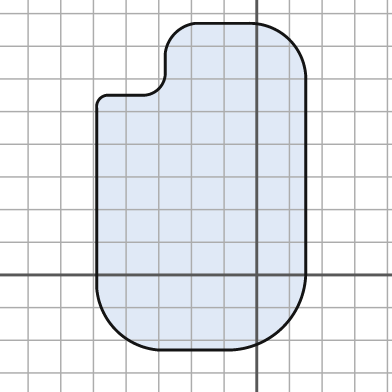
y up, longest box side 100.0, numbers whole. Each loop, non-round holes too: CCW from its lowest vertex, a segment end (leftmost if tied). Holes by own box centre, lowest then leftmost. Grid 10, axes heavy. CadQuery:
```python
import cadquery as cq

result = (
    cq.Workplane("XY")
    .moveTo(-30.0, -23.0)
    .lineTo(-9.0, -23.0)
    .threePointArc((8.0, -16.0), (15.0, 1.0))
    .lineTo(15.0, 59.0)
    .threePointArc((10.0, 72.0), (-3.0, 77.0))
    .lineTo(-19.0, 77.0)
    .threePointArc((-25.0, 74.0), (-28.0, 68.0))
    .lineTo(-28.0, 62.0)
    .threePointArc((-30.0, 57.0), (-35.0, 55.0))
    .lineTo(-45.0, 55.0)
    .threePointArc((-48.0, 54.0), (-49.0, 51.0))
    .lineTo(-49.0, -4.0)
    .threePointArc((-43.0, -17.0), (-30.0, -23.0))
    .close()
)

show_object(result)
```